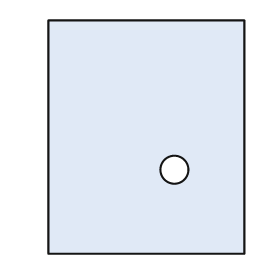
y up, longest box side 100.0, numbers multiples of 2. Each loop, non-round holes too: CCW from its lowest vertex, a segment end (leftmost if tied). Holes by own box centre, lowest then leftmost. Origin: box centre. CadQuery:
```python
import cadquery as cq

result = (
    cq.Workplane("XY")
    .moveTo(-42.0, -50.0)
    .lineTo(42.0, -50.0)
    .lineTo(42.0, 50.0)
    .lineTo(-42.0, 50.0)
    .close()
    .moveTo(12.0, -14.0)
    .circle(6.0)
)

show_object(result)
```